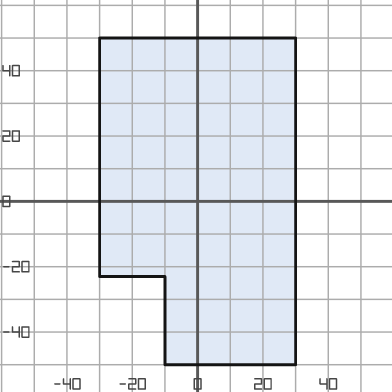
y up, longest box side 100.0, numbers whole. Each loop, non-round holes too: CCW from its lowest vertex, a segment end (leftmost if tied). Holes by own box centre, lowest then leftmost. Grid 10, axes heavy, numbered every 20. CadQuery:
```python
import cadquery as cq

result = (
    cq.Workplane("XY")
    .moveTo(-10.0, -50.0)
    .lineTo(30.0, -50.0)
    .lineTo(30.0, 50.0)
    .lineTo(-30.0, 50.0)
    .lineTo(-30.0, -23.0)
    .lineTo(-10.0, -23.0)
    .close()
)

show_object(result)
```